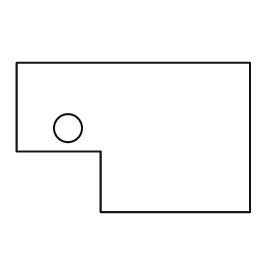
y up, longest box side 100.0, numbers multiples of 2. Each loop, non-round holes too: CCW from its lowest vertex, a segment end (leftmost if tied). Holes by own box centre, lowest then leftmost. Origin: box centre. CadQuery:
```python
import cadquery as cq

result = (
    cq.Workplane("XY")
    .moveTo(-14.0, -32.0)
    .lineTo(50.0, -32.0)
    .lineTo(50.0, 32.0)
    .lineTo(-50.0, 32.0)
    .lineTo(-50.0, -6.0)
    .lineTo(-14.0, -6.0)
    .close()
    .moveTo(-28.0, 4.0)
    .circle(6.0)
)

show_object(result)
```